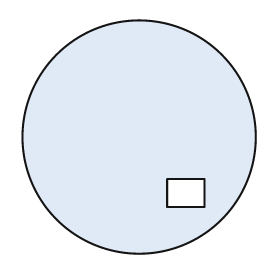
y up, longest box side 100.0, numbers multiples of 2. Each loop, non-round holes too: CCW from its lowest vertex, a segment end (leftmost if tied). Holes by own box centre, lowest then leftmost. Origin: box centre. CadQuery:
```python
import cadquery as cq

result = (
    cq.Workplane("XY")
    .moveTo(0.0, 0.0)
    .circle(50.0)
    .moveTo(12.0, -30.0)
    .lineTo(28.0, -30.0)
    .lineTo(28.0, -18.0)
    .lineTo(12.0, -18.0)
    .close()
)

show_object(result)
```